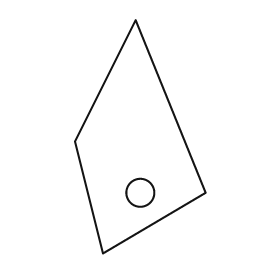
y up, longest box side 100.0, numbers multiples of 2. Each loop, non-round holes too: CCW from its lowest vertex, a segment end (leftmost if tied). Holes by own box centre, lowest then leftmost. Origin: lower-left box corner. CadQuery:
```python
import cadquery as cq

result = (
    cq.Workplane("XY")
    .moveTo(12.0, 0.0)
    .lineTo(56.0, 26.0)
    .lineTo(26.0, 100.0)
    .lineTo(0.0, 48.0)
    .close()
    .moveTo(28.0, 26.0)
    .circle(6.0)
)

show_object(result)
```